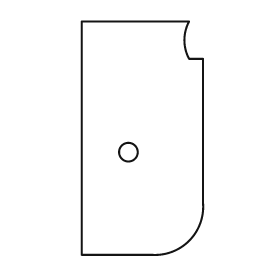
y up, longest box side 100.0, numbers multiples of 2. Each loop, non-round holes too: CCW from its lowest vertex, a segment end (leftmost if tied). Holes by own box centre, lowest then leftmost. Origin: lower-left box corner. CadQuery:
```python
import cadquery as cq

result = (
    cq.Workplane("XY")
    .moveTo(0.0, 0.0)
    .lineTo(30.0, 0.0)
    .threePointArc((46.0, 6.0), (52.0, 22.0))
    .lineTo(52.0, 84.0)
    .lineTo(46.0, 84.0)
    .threePointArc((44.0, 92.0), (46.0, 100.0))
    .lineTo(0.0, 100.0)
    .close()
    .moveTo(20.0, 44.0)
    .circle(4.0)
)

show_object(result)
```